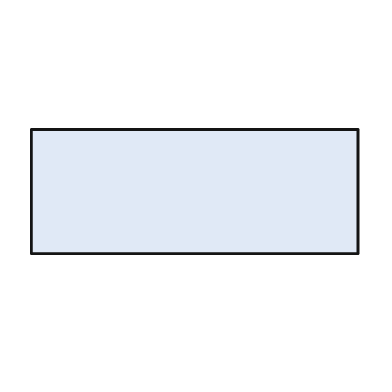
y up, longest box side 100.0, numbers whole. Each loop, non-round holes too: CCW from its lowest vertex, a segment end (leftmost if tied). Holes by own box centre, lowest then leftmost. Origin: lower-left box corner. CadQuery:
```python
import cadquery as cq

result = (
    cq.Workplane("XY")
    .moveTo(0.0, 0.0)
    .lineTo(100.0, 0.0)
    .lineTo(100.0, 38.0)
    .lineTo(0.0, 38.0)
    .close()
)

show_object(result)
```